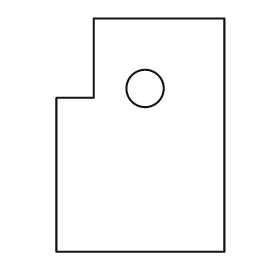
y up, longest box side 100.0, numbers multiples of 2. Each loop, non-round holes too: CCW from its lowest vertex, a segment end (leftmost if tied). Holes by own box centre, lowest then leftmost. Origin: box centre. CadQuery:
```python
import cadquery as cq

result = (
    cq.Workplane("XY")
    .moveTo(-36.0, -50.0)
    .lineTo(36.0, -50.0)
    .lineTo(36.0, 50.0)
    .lineTo(-20.0, 50.0)
    .lineTo(-20.0, 16.0)
    .lineTo(-36.0, 16.0)
    .close()
    .moveTo(2.0, 20.0)
    .circle(8.0)
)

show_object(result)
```